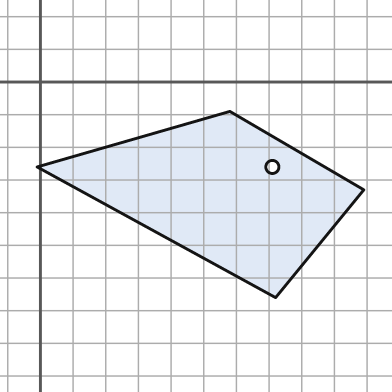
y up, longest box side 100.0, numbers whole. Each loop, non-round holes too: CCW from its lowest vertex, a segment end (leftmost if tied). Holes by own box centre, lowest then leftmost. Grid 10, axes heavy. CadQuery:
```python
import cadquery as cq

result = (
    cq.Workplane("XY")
    .moveTo(72.0, -66.0)
    .lineTo(99.0, -33.0)
    .lineTo(58.0, -9.0)
    .lineTo(-1.0, -26.0)
    .close()
    .moveTo(71.0, -26.0)
    .circle(2.0)
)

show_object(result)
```